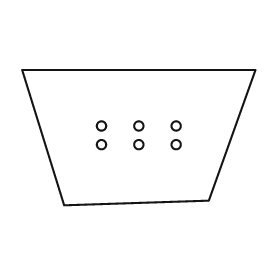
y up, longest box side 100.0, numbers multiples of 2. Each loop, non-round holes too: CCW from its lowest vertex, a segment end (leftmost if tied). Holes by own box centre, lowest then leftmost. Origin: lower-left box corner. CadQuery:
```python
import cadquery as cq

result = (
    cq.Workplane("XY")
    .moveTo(18.0, 0.0)
    .lineTo(80.0, 2.0)
    .lineTo(100.0, 58.0)
    .lineTo(0.0, 58.0)
    .close()
    .moveTo(34.0, 26.0)
    .circle(2.0)
    .moveTo(50.0, 26.0)
    .circle(2.0)
    .moveTo(66.0, 26.0)
    .circle(2.0)
    .moveTo(34.0, 34.0)
    .circle(2.0)
    .moveTo(50.0, 34.0)
    .circle(2.0)
    .moveTo(66.0, 34.0)
    .circle(2.0)
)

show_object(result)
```